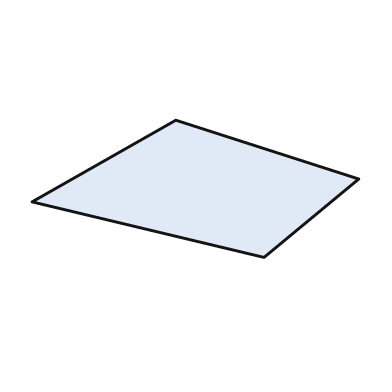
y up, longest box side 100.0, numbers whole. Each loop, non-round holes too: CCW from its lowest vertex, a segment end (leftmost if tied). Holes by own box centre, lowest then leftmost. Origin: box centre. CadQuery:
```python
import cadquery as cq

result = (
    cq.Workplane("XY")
    .moveTo(21.0, -21.0)
    .lineTo(50.0, 3.0)
    .lineTo(-6.0, 21.0)
    .lineTo(-50.0, -4.0)
    .close()
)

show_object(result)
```